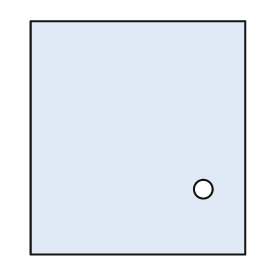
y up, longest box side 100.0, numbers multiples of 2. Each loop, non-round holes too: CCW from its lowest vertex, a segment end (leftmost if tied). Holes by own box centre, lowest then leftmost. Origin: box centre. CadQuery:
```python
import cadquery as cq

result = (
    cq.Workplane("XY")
    .moveTo(-46.0, -50.0)
    .lineTo(46.0, -50.0)
    .lineTo(46.0, 50.0)
    .lineTo(-46.0, 50.0)
    .close()
    .moveTo(28.0, -22.0)
    .circle(4.0)
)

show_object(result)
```